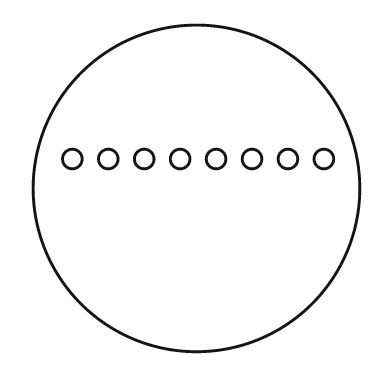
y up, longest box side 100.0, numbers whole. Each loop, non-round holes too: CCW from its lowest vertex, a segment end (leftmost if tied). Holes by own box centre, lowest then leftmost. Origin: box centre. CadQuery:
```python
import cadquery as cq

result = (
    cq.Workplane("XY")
    .moveTo(0.0, 0.0)
    .circle(50.0)
    .moveTo(-38.0, 9.0)
    .circle(3.0)
    .moveTo(-27.0, 9.0)
    .circle(3.0)
    .moveTo(-16.0, 9.0)
    .circle(3.0)
    .moveTo(-5.0, 9.0)
    .circle(3.0)
    .moveTo(6.0, 9.0)
    .circle(3.0)
    .moveTo(17.0, 9.0)
    .circle(3.0)
    .moveTo(28.0, 9.0)
    .circle(3.0)
    .moveTo(39.0, 9.0)
    .circle(3.0)
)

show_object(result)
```